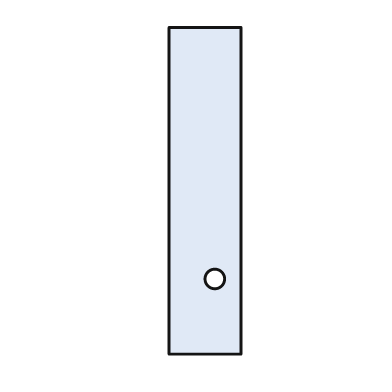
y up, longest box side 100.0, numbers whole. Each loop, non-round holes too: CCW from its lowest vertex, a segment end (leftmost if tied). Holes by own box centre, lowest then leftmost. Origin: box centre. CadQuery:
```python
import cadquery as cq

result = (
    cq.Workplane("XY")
    .moveTo(-11.0, -50.0)
    .lineTo(11.0, -50.0)
    .lineTo(11.0, 50.0)
    .lineTo(-11.0, 50.0)
    .close()
    .moveTo(3.0, -27.0)
    .circle(3.0)
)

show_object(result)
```